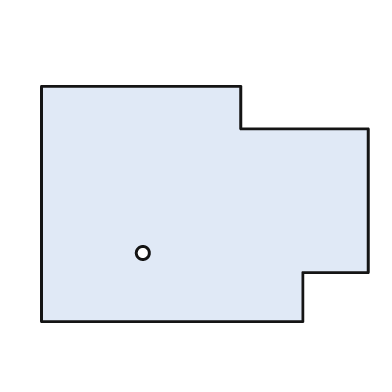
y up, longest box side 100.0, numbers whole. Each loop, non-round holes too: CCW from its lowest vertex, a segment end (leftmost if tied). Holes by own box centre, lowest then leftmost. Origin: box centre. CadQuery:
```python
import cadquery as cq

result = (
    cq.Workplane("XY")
    .moveTo(-50.0, -36.0)
    .lineTo(30.0, -36.0)
    .lineTo(30.0, -21.0)
    .lineTo(50.0, -21.0)
    .lineTo(50.0, 23.0)
    .lineTo(11.0, 23.0)
    .lineTo(11.0, 36.0)
    .lineTo(-50.0, 36.0)
    .close()
    .moveTo(-19.0, -15.0)
    .circle(2.0)
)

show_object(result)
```